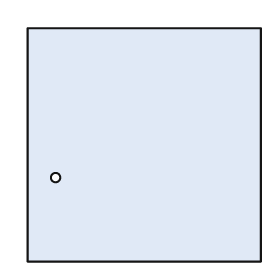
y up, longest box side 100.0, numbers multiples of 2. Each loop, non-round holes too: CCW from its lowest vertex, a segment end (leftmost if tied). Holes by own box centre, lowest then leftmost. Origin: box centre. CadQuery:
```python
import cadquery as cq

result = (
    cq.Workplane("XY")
    .moveTo(-50.0, -50.0)
    .lineTo(50.0, -50.0)
    .lineTo(50.0, 50.0)
    .lineTo(-50.0, 50.0)
    .close()
    .moveTo(-38.0, -14.0)
    .circle(2.0)
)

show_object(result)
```